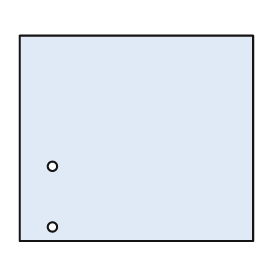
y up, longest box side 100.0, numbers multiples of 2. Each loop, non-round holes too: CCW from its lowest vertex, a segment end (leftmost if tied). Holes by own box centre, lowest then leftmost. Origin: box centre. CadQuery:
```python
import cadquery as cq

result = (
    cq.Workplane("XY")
    .moveTo(-50.0, -44.0)
    .lineTo(50.0, -44.0)
    .lineTo(50.0, 44.0)
    .lineTo(-50.0, 44.0)
    .close()
    .moveTo(-36.0, -38.0)
    .circle(2.0)
    .moveTo(-36.0, -12.0)
    .circle(2.0)
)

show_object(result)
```